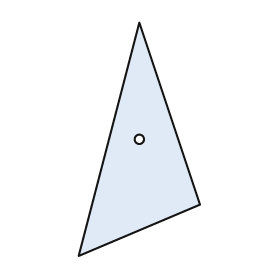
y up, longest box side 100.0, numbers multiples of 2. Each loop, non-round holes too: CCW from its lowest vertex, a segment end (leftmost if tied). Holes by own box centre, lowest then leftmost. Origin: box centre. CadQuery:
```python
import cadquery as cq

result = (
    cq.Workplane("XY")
    .moveTo(-26.0, -50.0)
    .lineTo(26.0, -28.0)
    .lineTo(0.0, 50.0)
    .close()
    .moveTo(0.0, 0.0)
    .circle(2.0)
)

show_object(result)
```